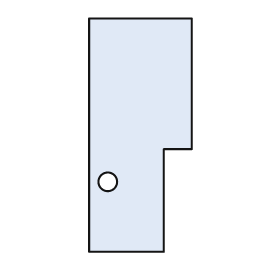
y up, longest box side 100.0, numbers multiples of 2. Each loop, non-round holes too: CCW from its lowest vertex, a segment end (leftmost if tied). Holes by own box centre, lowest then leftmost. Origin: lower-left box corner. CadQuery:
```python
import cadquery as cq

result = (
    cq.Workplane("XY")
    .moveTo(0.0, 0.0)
    .lineTo(32.0, 0.0)
    .lineTo(32.0, 44.0)
    .lineTo(44.0, 44.0)
    .lineTo(44.0, 100.0)
    .lineTo(0.0, 100.0)
    .close()
    .moveTo(8.0, 30.0)
    .circle(4.0)
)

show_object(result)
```